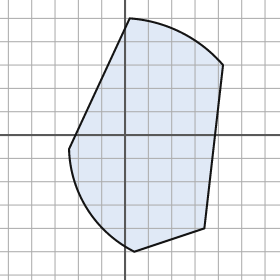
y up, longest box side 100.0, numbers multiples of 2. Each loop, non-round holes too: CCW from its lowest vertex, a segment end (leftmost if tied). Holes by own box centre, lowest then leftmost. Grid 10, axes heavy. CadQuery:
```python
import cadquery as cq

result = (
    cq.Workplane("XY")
    .moveTo(4.0, -50.0)
    .lineTo(34.0, -40.0)
    .lineTo(42.0, 30.0)
    .threePointArc((24.0, 44.0), (2.0, 50.0))
    .lineTo(-24.0, -6.0)
    .threePointArc((-16.0, -32.0), (4.0, -50.0))
    .close()
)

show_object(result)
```